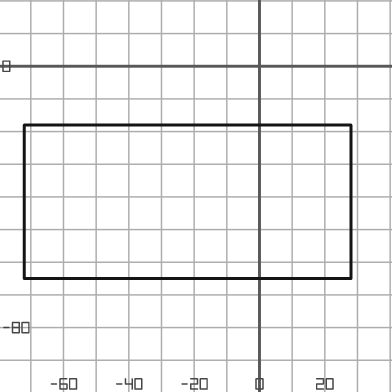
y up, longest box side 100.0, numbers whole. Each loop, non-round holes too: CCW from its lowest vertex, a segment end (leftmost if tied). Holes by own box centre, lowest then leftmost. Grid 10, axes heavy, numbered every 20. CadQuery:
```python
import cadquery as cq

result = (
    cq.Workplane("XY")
    .moveTo(-72.0, -65.0)
    .lineTo(28.0, -65.0)
    .lineTo(28.0, -18.0)
    .lineTo(-72.0, -18.0)
    .close()
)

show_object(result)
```